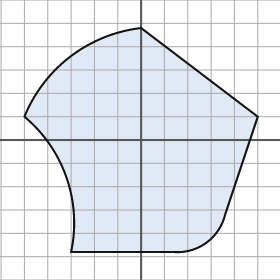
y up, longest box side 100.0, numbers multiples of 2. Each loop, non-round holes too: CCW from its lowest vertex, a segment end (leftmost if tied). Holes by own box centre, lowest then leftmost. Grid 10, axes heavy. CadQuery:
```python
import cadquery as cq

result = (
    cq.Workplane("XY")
    .moveTo(-30.0, -48.0)
    .lineTo(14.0, -48.0)
    .threePointArc((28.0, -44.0), (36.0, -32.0))
    .lineTo(50.0, 10.0)
    .lineTo(0.0, 48.0)
    .threePointArc((-30.0, 36.0), (-50.0, 10.0))
    .threePointArc((-32.0, -16.0), (-30.0, -48.0))
    .close()
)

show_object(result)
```